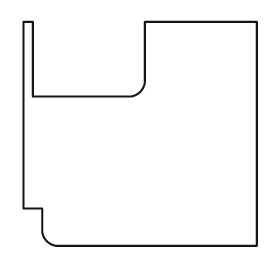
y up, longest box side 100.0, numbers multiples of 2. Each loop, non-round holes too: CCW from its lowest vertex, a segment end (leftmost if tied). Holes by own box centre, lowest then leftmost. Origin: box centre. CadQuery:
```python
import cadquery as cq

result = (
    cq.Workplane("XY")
    .moveTo(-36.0, -48.0)
    .lineTo(50.0, -48.0)
    .lineTo(50.0, 48.0)
    .lineTo(2.0, 48.0)
    .lineTo(2.0, 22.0)
    .threePointArc((0.0, 18.0), (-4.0, 16.0))
    .lineTo(-46.0, 16.0)
    .lineTo(-46.0, 48.0)
    .lineTo(-50.0, 48.0)
    .lineTo(-50.0, -32.0)
    .lineTo(-42.0, -32.0)
    .lineTo(-42.0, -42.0)
    .threePointArc((-40.0, -46.0), (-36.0, -48.0))
    .close()
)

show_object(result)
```